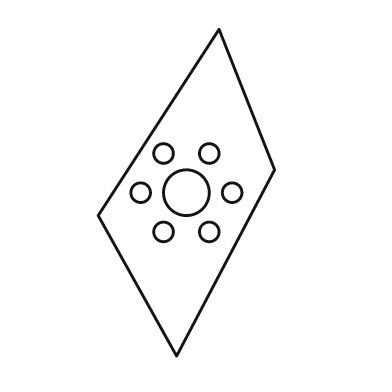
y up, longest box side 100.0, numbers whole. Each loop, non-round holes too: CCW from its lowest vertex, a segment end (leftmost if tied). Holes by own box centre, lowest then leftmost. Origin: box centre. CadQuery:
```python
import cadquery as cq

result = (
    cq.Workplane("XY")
    .moveTo(-3.0, -50.0)
    .lineTo(27.0, 7.0)
    .lineTo(10.0, 50.0)
    .lineTo(-27.0, -7.0)
    .close()
    .moveTo(-7.0, -12.0)
    .circle(3.0)
    .moveTo(7.0, -12.0)
    .circle(3.0)
    .moveTo(-14.0, 0.0)
    .circle(3.0)
    .moveTo(0.0, 0.0)
    .circle(7.0)
    .moveTo(14.0, 0.0)
    .circle(3.0)
    .moveTo(-7.0, 12.0)
    .circle(3.0)
    .moveTo(7.0, 12.0)
    .circle(3.0)
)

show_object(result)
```